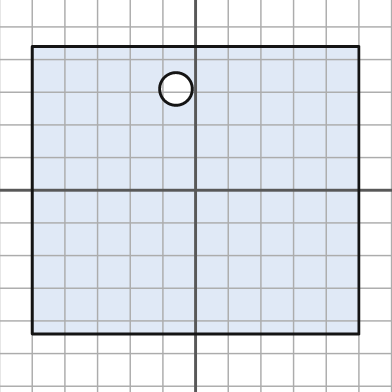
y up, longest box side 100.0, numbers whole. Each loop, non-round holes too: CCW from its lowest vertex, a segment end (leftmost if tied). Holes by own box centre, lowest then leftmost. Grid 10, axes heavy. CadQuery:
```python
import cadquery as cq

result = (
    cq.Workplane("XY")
    .moveTo(-50.0, -44.0)
    .lineTo(50.0, -44.0)
    .lineTo(50.0, 44.0)
    .lineTo(-50.0, 44.0)
    .close()
    .moveTo(-6.0, 31.0)
    .circle(5.0)
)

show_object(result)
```